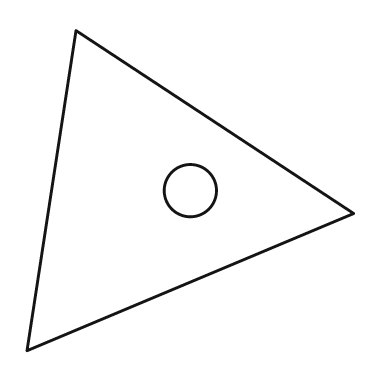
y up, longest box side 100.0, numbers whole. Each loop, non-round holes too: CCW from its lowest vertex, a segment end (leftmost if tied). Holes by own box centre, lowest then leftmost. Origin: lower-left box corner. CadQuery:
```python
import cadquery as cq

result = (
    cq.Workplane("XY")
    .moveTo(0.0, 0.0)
    .lineTo(100.0, 42.0)
    .lineTo(15.0, 98.0)
    .close()
    .moveTo(50.0, 49.0)
    .circle(8.0)
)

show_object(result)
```